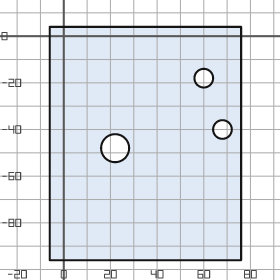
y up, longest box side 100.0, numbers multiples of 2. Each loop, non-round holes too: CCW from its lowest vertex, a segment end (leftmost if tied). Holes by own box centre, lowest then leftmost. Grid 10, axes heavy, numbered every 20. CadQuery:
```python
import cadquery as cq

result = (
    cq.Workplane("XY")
    .moveTo(-6.0, -96.0)
    .lineTo(76.0, -96.0)
    .lineTo(76.0, 4.0)
    .lineTo(-6.0, 4.0)
    .close()
    .moveTo(22.0, -48.0)
    .circle(6.0)
    .moveTo(68.0, -40.0)
    .circle(4.0)
    .moveTo(60.0, -18.0)
    .circle(4.0)
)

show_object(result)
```